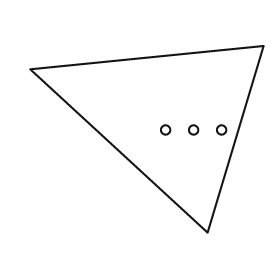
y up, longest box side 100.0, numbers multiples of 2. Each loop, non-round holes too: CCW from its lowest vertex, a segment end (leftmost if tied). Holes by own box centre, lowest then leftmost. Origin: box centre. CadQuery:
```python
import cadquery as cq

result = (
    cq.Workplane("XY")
    .moveTo(26.0, -40.0)
    .lineTo(50.0, 40.0)
    .lineTo(-50.0, 30.0)
    .close()
    .moveTo(8.0, 4.0)
    .circle(2.0)
    .moveTo(20.0, 4.0)
    .circle(2.0)
    .moveTo(32.0, 4.0)
    .circle(2.0)
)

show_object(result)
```